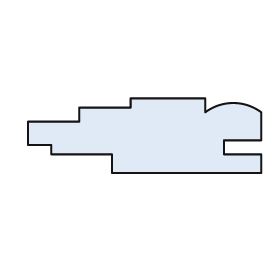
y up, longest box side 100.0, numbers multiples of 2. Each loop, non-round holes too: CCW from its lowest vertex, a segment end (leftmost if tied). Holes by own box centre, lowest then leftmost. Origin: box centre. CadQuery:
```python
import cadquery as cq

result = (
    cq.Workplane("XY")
    .moveTo(-14.0, -16.0)
    .lineTo(50.0, -16.0)
    .lineTo(50.0, -8.0)
    .lineTo(34.0, -8.0)
    .lineTo(34.0, -2.0)
    .lineTo(50.0, -2.0)
    .lineTo(50.0, 10.0)
    .threePointArc((38.0, 14.0), (26.0, 10.0))
    .lineTo(26.0, 16.0)
    .lineTo(-6.0, 16.0)
    .lineTo(-6.0, 12.0)
    .lineTo(-28.0, 12.0)
    .lineTo(-28.0, 6.0)
    .lineTo(-50.0, 6.0)
    .lineTo(-50.0, -4.0)
    .lineTo(-40.0, -4.0)
    .lineTo(-40.0, -8.0)
    .lineTo(-14.0, -8.0)
    .close()
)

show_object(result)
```